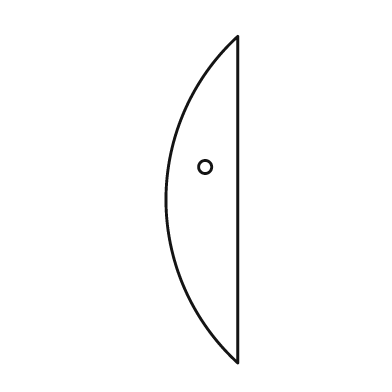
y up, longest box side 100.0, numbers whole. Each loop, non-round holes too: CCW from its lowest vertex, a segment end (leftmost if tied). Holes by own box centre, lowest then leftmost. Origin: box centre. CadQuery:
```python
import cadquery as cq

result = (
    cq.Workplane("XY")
    .moveTo(11.0, -50.0)
    .lineTo(11.0, 50.0)
    .threePointArc((-11.0, 0.0), (11.0, -50.0))
    .close()
    .moveTo(1.0, 10.0)
    .circle(2.0)
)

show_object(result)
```